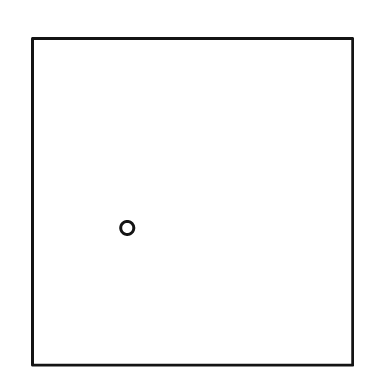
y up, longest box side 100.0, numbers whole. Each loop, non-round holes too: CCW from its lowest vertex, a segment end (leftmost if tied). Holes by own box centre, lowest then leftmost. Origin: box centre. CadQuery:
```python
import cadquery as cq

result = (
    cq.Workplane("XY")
    .moveTo(-49.0, -50.0)
    .lineTo(49.0, -50.0)
    .lineTo(49.0, 50.0)
    .lineTo(-49.0, 50.0)
    .close()
    .moveTo(-20.0, -8.0)
    .circle(2.0)
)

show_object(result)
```